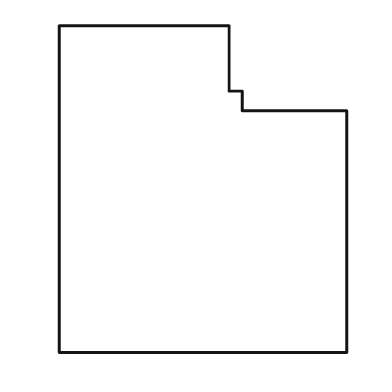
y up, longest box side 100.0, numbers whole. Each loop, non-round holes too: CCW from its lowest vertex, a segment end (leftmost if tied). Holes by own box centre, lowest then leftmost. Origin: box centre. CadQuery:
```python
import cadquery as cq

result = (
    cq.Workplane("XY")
    .moveTo(-44.0, -50.0)
    .lineTo(44.0, -50.0)
    .lineTo(44.0, 24.0)
    .lineTo(12.0, 24.0)
    .lineTo(12.0, 30.0)
    .lineTo(8.0, 30.0)
    .lineTo(8.0, 50.0)
    .lineTo(-44.0, 50.0)
    .close()
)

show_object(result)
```